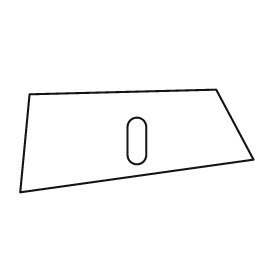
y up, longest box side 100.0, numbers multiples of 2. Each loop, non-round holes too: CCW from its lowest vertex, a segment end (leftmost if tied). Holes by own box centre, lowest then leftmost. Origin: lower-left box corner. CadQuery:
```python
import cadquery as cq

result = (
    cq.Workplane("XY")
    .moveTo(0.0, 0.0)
    .lineTo(100.0, 14.0)
    .lineTo(84.0, 44.0)
    .lineTo(4.0, 42.0)
    .close()
    .moveTo(46.0, 16.0)
    .threePointArc((50.0, 12.0), (54.0, 16.0))
    .lineTo(54.0, 28.0)
    .threePointArc((50.0, 32.0), (46.0, 28.0))
    .close()
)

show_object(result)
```